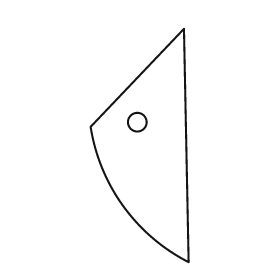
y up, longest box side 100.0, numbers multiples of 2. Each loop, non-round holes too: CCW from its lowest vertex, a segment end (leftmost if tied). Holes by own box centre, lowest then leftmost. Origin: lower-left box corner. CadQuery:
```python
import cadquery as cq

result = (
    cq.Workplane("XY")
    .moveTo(42.0, 0.0)
    .lineTo(40.0, 100.0)
    .lineTo(0.0, 58.0)
    .threePointArc((14.0, 24.0), (42.0, 0.0))
    .close()
    .moveTo(20.0, 60.0)
    .circle(4.0)
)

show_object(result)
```